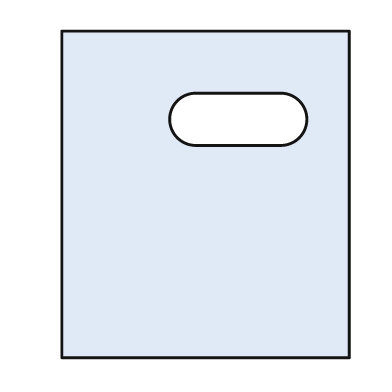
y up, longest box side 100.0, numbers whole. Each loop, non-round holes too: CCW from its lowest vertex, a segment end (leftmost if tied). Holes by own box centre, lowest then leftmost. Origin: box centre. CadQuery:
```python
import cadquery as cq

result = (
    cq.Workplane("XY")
    .moveTo(-44.0, -50.0)
    .lineTo(44.0, -50.0)
    .lineTo(44.0, 50.0)
    .lineTo(-44.0, 50.0)
    .close()
    .moveTo(-3.0, 15.0)
    .lineTo(23.0, 15.0)
    .threePointArc((31.0, 23.0), (23.0, 31.0))
    .lineTo(-3.0, 31.0)
    .threePointArc((-11.0, 23.0), (-3.0, 15.0))
    .close()
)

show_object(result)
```